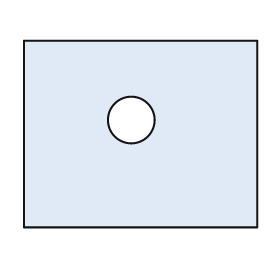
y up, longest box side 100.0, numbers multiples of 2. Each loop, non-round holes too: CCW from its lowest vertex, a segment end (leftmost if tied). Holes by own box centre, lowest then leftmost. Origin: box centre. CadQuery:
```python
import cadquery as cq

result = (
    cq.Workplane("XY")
    .moveTo(-50.0, -40.0)
    .lineTo(50.0, -40.0)
    .lineTo(50.0, 40.0)
    .lineTo(-50.0, 40.0)
    .close()
    .moveTo(-4.0, 6.0)
    .circle(10.0)
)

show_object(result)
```